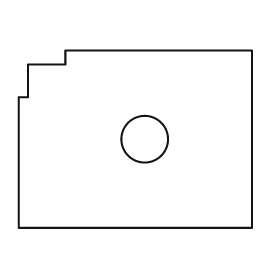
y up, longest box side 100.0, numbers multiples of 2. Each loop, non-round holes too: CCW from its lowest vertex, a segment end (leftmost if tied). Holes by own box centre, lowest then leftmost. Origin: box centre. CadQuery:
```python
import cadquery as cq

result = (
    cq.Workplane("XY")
    .moveTo(-50.0, -38.0)
    .lineTo(50.0, -38.0)
    .lineTo(50.0, 38.0)
    .lineTo(-30.0, 38.0)
    .lineTo(-30.0, 32.0)
    .lineTo(-46.0, 32.0)
    .lineTo(-46.0, 18.0)
    .lineTo(-50.0, 18.0)
    .close()
    .moveTo(4.0, 0.0)
    .circle(10.0)
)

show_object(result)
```